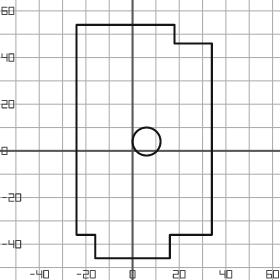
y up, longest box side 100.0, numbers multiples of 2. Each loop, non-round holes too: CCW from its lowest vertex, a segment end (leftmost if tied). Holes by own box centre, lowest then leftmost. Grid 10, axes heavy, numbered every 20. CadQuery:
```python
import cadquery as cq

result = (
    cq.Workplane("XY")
    .moveTo(-16.0, -46.0)
    .lineTo(16.0, -46.0)
    .lineTo(16.0, -36.0)
    .lineTo(34.0, -36.0)
    .lineTo(34.0, 46.0)
    .lineTo(18.0, 46.0)
    .lineTo(18.0, 54.0)
    .lineTo(-24.0, 54.0)
    .lineTo(-24.0, -36.0)
    .lineTo(-16.0, -36.0)
    .close()
    .moveTo(6.0, 4.0)
    .circle(6.0)
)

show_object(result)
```